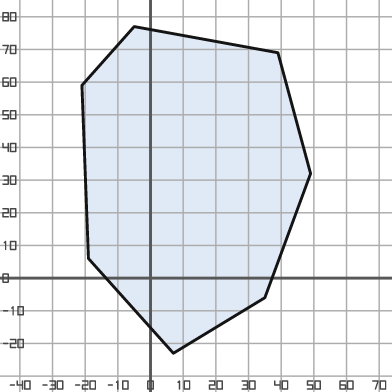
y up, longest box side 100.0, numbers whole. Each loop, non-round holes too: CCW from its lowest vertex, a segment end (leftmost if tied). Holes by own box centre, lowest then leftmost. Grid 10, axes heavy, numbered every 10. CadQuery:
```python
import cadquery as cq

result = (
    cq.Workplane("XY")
    .moveTo(7.0, -23.0)
    .lineTo(35.0, -6.0)
    .lineTo(49.0, 32.0)
    .lineTo(39.0, 69.0)
    .lineTo(-5.0, 77.0)
    .lineTo(-21.0, 59.0)
    .lineTo(-19.0, 6.0)
    .close()
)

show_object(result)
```